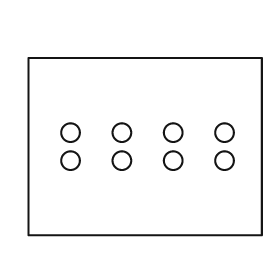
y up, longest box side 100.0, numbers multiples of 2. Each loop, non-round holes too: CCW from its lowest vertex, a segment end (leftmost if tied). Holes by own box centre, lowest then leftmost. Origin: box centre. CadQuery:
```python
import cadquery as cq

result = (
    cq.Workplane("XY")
    .moveTo(-50.0, -38.0)
    .lineTo(50.0, -38.0)
    .lineTo(50.0, 38.0)
    .lineTo(-50.0, 38.0)
    .close()
    .moveTo(-32.0, -6.0)
    .circle(4.0)
    .moveTo(-10.0, -6.0)
    .circle(4.0)
    .moveTo(12.0, -6.0)
    .circle(4.0)
    .moveTo(34.0, -6.0)
    .circle(4.0)
    .moveTo(-32.0, 6.0)
    .circle(4.0)
    .moveTo(-10.0, 6.0)
    .circle(4.0)
    .moveTo(12.0, 6.0)
    .circle(4.0)
    .moveTo(34.0, 6.0)
    .circle(4.0)
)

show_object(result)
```